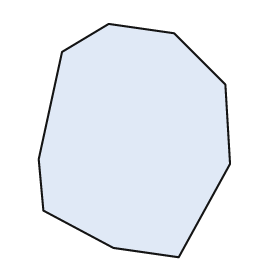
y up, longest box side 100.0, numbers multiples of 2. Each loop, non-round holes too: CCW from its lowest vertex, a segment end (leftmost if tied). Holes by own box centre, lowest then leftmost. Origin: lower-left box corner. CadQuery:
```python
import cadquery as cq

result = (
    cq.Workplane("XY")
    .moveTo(60.0, 0.0)
    .lineTo(82.0, 40.0)
    .lineTo(80.0, 74.0)
    .lineTo(58.0, 96.0)
    .lineTo(30.0, 100.0)
    .lineTo(10.0, 88.0)
    .lineTo(0.0, 42.0)
    .lineTo(2.0, 20.0)
    .lineTo(32.0, 4.0)
    .close()
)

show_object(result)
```